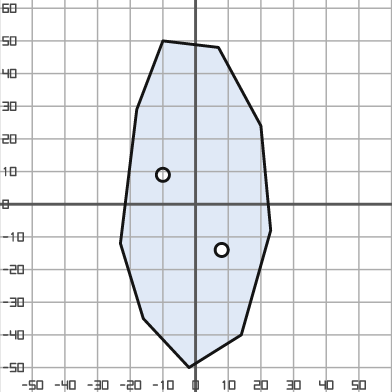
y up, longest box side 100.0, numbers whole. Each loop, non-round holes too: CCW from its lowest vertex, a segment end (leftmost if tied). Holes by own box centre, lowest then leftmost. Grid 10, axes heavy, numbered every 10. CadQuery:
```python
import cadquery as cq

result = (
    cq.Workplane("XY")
    .moveTo(-2.0, -50.0)
    .lineTo(14.0, -40.0)
    .lineTo(23.0, -8.0)
    .lineTo(20.0, 24.0)
    .lineTo(7.0, 48.0)
    .lineTo(-10.0, 50.0)
    .lineTo(-18.0, 29.0)
    .lineTo(-23.0, -12.0)
    .lineTo(-16.0, -35.0)
    .close()
    .moveTo(8.0, -14.0)
    .circle(2.0)
    .moveTo(-10.0, 9.0)
    .circle(2.0)
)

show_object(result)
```